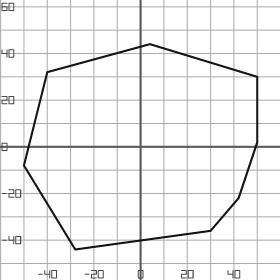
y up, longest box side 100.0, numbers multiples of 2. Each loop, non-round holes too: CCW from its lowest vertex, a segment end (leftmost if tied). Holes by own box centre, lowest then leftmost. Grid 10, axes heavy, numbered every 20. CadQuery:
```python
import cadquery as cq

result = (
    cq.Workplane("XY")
    .moveTo(-28.0, -44.0)
    .lineTo(30.0, -36.0)
    .lineTo(42.0, -22.0)
    .lineTo(50.0, 2.0)
    .lineTo(50.0, 30.0)
    .lineTo(4.0, 44.0)
    .lineTo(-40.0, 32.0)
    .lineTo(-50.0, -8.0)
    .close()
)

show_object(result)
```